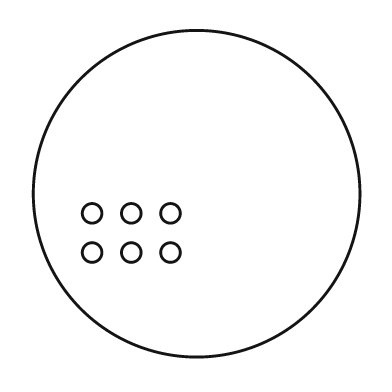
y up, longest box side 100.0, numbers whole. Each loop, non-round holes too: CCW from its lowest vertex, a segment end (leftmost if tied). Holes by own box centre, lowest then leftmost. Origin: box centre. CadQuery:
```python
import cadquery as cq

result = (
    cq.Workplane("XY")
    .moveTo(0.0, 0.0)
    .circle(50.0)
    .moveTo(-32.0, -18.0)
    .circle(3.0)
    .moveTo(-20.0, -18.0)
    .circle(3.0)
    .moveTo(-8.0, -18.0)
    .circle(3.0)
    .moveTo(-32.0, -6.0)
    .circle(3.0)
    .moveTo(-20.0, -6.0)
    .circle(3.0)
    .moveTo(-8.0, -6.0)
    .circle(3.0)
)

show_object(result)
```